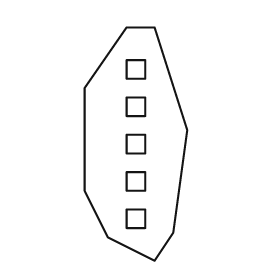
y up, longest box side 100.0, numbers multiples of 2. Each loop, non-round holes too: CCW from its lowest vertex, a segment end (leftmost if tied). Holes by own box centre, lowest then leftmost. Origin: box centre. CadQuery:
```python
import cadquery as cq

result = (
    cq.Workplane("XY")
    .moveTo(8.0, -50.0)
    .lineTo(16.0, -38.0)
    .lineTo(22.0, 6.0)
    .lineTo(8.0, 50.0)
    .lineTo(-4.0, 50.0)
    .lineTo(-22.0, 24.0)
    .lineTo(-22.0, -20.0)
    .lineTo(-12.0, -40.0)
    .close()
    .moveTo(-4.0, -36.0)
    .lineTo(4.0, -36.0)
    .lineTo(4.0, -28.0)
    .lineTo(-4.0, -28.0)
    .close()
    .moveTo(-4.0, -20.0)
    .lineTo(4.0, -20.0)
    .lineTo(4.0, -12.0)
    .lineTo(-4.0, -12.0)
    .close()
    .moveTo(-4.0, -4.0)
    .lineTo(4.0, -4.0)
    .lineTo(4.0, 4.0)
    .lineTo(-4.0, 4.0)
    .close()
    .moveTo(-4.0, 12.0)
    .lineTo(4.0, 12.0)
    .lineTo(4.0, 20.0)
    .lineTo(-4.0, 20.0)
    .close()
    .moveTo(-4.0, 28.0)
    .lineTo(4.0, 28.0)
    .lineTo(4.0, 36.0)
    .lineTo(-4.0, 36.0)
    .close()
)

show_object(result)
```